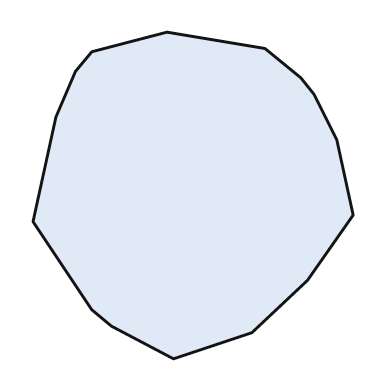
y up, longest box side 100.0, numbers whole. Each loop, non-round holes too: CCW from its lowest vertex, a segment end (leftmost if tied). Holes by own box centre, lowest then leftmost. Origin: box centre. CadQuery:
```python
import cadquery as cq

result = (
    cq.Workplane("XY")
    .moveTo(-6.0, -50.0)
    .lineTo(18.0, -42.0)
    .lineTo(35.0, -26.0)
    .lineTo(49.0, -6.0)
    .lineTo(44.0, 17.0)
    .lineTo(37.0, 31.0)
    .lineTo(33.0, 36.0)
    .lineTo(22.0, 45.0)
    .lineTo(-8.0, 50.0)
    .lineTo(-31.0, 44.0)
    .lineTo(-36.0, 38.0)
    .lineTo(-42.0, 24.0)
    .lineTo(-49.0, -8.0)
    .lineTo(-31.0, -35.0)
    .lineTo(-25.0, -40.0)
    .close()
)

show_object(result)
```